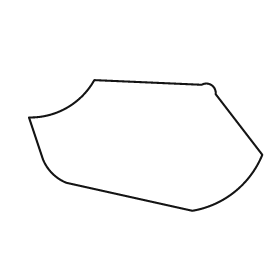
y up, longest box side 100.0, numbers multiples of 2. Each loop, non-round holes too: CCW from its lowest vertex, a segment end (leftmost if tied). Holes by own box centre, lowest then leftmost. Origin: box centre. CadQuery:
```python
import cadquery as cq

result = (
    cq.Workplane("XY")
    .moveTo(20.0, -28.0)
    .threePointArc((38.0, -20.0), (50.0, -4.0))
    .lineTo(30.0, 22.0)
    .threePointArc((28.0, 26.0), (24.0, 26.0))
    .lineTo(-22.0, 28.0)
    .threePointArc((-34.0, 16.0), (-50.0, 12.0))
    .lineTo(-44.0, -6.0)
    .threePointArc((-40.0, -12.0), (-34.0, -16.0))
    .close()
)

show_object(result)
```